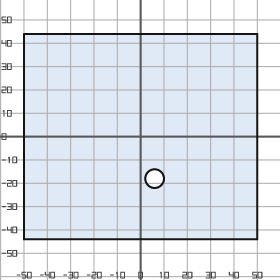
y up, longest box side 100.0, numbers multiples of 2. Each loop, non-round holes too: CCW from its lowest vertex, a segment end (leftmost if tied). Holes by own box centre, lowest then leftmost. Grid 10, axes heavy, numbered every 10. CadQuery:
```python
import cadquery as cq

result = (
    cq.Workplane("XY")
    .moveTo(-50.0, -44.0)
    .lineTo(50.0, -44.0)
    .lineTo(50.0, 44.0)
    .lineTo(-50.0, 44.0)
    .close()
    .moveTo(6.0, -18.0)
    .circle(4.0)
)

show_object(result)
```